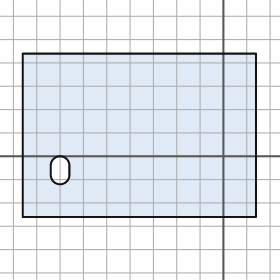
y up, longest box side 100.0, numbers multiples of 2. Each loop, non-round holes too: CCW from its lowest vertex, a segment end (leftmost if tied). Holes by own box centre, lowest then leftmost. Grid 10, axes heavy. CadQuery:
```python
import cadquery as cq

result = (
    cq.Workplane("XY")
    .moveTo(-86.0, -26.0)
    .lineTo(14.0, -26.0)
    .lineTo(14.0, 44.0)
    .lineTo(-86.0, 44.0)
    .close()
    .moveTo(-74.0, -8.0)
    .threePointArc((-70.0, -12.0), (-66.0, -8.0))
    .lineTo(-66.0, -4.0)
    .threePointArc((-70.0, 0.0), (-74.0, -4.0))
    .close()
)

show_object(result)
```